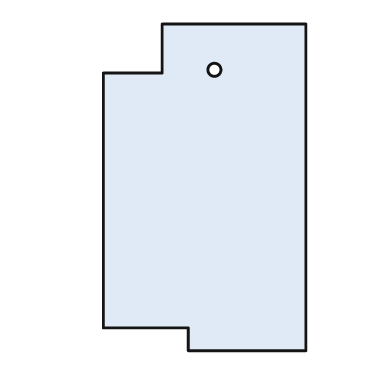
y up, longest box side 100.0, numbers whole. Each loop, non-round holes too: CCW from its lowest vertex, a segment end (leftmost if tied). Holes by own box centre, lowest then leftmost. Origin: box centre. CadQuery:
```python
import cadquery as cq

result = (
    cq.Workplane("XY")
    .moveTo(-5.0, -50.0)
    .lineTo(31.0, -50.0)
    .lineTo(31.0, 50.0)
    .lineTo(-13.0, 50.0)
    .lineTo(-13.0, 35.0)
    .lineTo(-31.0, 35.0)
    .lineTo(-31.0, -43.0)
    .lineTo(-5.0, -43.0)
    .close()
    .moveTo(3.0, 36.0)
    .circle(2.0)
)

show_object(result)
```